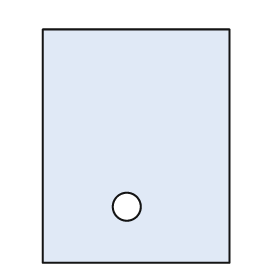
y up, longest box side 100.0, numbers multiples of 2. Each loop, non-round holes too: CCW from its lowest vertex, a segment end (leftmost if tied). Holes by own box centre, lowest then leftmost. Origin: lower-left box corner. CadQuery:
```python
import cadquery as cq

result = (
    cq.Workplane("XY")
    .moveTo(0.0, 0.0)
    .lineTo(80.0, 0.0)
    .lineTo(80.0, 100.0)
    .lineTo(0.0, 100.0)
    .close()
    .moveTo(36.0, 24.0)
    .circle(6.0)
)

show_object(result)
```